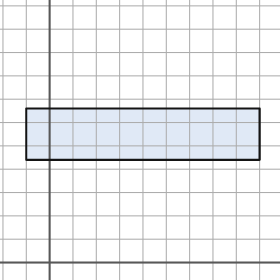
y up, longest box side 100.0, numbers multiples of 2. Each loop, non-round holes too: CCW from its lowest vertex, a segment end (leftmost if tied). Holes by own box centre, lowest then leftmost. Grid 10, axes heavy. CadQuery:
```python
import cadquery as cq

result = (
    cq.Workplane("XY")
    .moveTo(-10.0, 44.0)
    .lineTo(90.0, 44.0)
    .lineTo(90.0, 66.0)
    .lineTo(-10.0, 66.0)
    .close()
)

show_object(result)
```